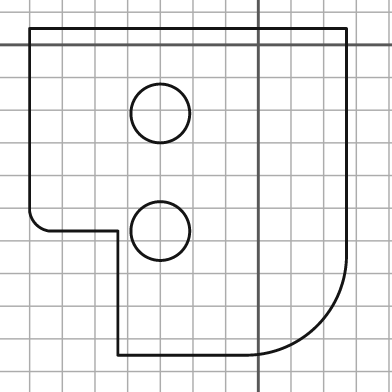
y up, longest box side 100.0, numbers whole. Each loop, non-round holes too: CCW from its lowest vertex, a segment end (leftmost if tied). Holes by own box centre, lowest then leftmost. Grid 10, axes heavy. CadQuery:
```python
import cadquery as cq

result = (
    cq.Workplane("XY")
    .moveTo(-43.0, -95.0)
    .lineTo(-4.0, -95.0)
    .threePointArc((18.0, -86.0), (27.0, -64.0))
    .lineTo(27.0, 5.0)
    .lineTo(-70.0, 5.0)
    .lineTo(-70.0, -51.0)
    .threePointArc((-68.0, -55.0), (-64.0, -57.0))
    .lineTo(-43.0, -57.0)
    .close()
    .moveTo(-30.0, -57.0)
    .circle(9.0)
    .moveTo(-30.0, -21.0)
    .circle(9.0)
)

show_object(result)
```